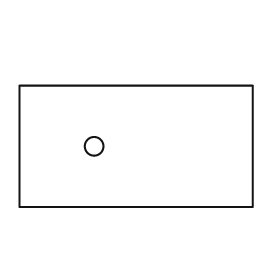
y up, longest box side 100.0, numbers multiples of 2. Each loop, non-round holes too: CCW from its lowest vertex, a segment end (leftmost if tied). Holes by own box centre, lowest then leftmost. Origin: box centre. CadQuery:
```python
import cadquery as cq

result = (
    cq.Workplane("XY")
    .moveTo(-50.0, -26.0)
    .lineTo(50.0, -26.0)
    .lineTo(50.0, 26.0)
    .lineTo(-50.0, 26.0)
    .close()
    .moveTo(-18.0, 0.0)
    .circle(4.0)
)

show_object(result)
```